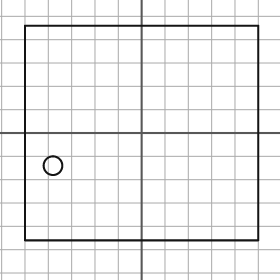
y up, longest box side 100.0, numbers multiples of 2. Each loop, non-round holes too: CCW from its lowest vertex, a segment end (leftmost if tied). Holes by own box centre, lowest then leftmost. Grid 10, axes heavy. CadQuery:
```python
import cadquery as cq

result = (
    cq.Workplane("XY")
    .moveTo(-50.0, -46.0)
    .lineTo(50.0, -46.0)
    .lineTo(50.0, 46.0)
    .lineTo(-50.0, 46.0)
    .close()
    .moveTo(-38.0, -14.0)
    .circle(4.0)
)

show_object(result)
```